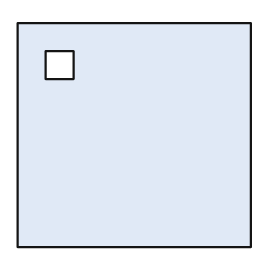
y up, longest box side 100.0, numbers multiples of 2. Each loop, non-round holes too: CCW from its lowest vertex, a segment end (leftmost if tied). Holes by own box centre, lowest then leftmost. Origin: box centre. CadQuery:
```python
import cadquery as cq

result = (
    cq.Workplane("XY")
    .moveTo(-50.0, -48.0)
    .lineTo(50.0, -48.0)
    .lineTo(50.0, 48.0)
    .lineTo(-50.0, 48.0)
    .close()
    .moveTo(-38.0, 24.0)
    .lineTo(-26.0, 24.0)
    .lineTo(-26.0, 36.0)
    .lineTo(-38.0, 36.0)
    .close()
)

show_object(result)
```